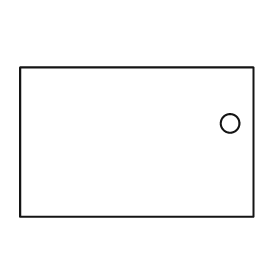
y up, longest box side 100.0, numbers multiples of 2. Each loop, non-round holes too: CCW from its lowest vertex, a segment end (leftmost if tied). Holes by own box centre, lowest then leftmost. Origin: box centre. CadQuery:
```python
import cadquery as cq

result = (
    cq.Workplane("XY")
    .moveTo(-50.0, -32.0)
    .lineTo(50.0, -32.0)
    .lineTo(50.0, 32.0)
    .lineTo(-50.0, 32.0)
    .close()
    .moveTo(40.0, 8.0)
    .circle(4.0)
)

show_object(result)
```